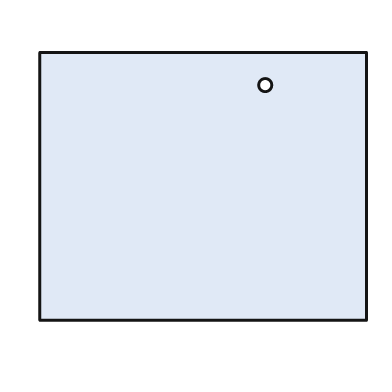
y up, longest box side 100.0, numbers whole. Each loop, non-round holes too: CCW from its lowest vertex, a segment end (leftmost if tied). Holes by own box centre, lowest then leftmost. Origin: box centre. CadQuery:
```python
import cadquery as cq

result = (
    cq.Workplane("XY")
    .moveTo(-50.0, -41.0)
    .lineTo(50.0, -41.0)
    .lineTo(50.0, 41.0)
    .lineTo(-50.0, 41.0)
    .close()
    .moveTo(19.0, 31.0)
    .circle(2.0)
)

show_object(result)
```